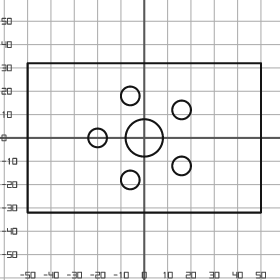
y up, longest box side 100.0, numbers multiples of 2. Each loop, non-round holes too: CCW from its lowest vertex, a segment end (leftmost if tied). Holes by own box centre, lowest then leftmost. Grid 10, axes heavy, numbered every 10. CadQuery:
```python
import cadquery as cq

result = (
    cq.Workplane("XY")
    .moveTo(-50.0, -32.0)
    .lineTo(50.0, -32.0)
    .lineTo(50.0, 32.0)
    .lineTo(-50.0, 32.0)
    .close()
    .moveTo(-6.0, -18.0)
    .circle(4.0)
    .moveTo(16.0, -12.0)
    .circle(4.0)
    .moveTo(-20.0, 0.0)
    .circle(4.0)
    .moveTo(0.0, 0.0)
    .circle(8.0)
    .moveTo(16.0, 12.0)
    .circle(4.0)
    .moveTo(-6.0, 18.0)
    .circle(4.0)
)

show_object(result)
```